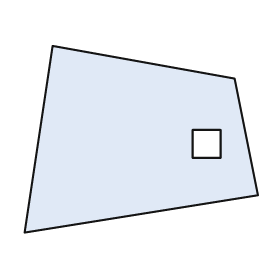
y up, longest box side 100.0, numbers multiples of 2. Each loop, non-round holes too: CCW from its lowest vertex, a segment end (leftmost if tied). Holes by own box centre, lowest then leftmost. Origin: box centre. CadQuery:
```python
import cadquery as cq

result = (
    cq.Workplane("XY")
    .moveTo(-50.0, -40.0)
    .lineTo(50.0, -24.0)
    .lineTo(40.0, 26.0)
    .lineTo(-38.0, 40.0)
    .close()
    .moveTo(22.0, -8.0)
    .lineTo(34.0, -8.0)
    .lineTo(34.0, 4.0)
    .lineTo(22.0, 4.0)
    .close()
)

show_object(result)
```